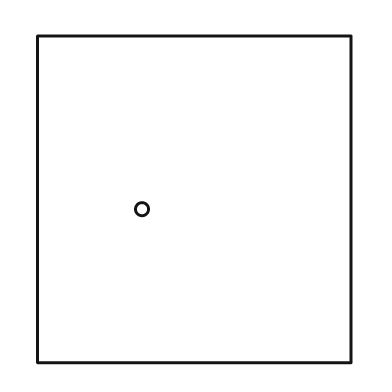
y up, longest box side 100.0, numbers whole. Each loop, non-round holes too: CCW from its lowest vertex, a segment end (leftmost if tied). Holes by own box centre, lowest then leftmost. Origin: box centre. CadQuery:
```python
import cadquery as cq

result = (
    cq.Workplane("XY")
    .moveTo(-48.0, -50.0)
    .lineTo(48.0, -50.0)
    .lineTo(48.0, 50.0)
    .lineTo(-48.0, 50.0)
    .close()
    .moveTo(-16.0, -3.0)
    .circle(2.0)
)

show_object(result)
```